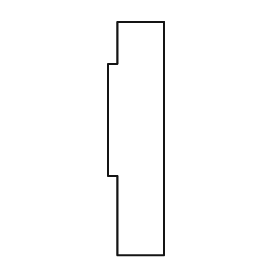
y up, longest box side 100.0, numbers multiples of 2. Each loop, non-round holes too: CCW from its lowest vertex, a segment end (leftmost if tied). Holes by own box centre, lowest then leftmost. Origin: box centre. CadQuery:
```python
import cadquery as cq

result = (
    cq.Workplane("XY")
    .moveTo(-8.0, -50.0)
    .lineTo(12.0, -50.0)
    .lineTo(12.0, 50.0)
    .lineTo(-8.0, 50.0)
    .lineTo(-8.0, 32.0)
    .lineTo(-12.0, 32.0)
    .lineTo(-12.0, -16.0)
    .lineTo(-8.0, -16.0)
    .close()
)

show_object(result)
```